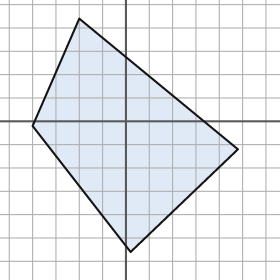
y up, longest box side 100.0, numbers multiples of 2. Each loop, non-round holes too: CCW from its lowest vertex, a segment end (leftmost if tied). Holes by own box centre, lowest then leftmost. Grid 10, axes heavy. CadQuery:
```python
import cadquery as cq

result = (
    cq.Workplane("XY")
    .moveTo(2.0, -56.0)
    .lineTo(48.0, -12.0)
    .lineTo(-20.0, 44.0)
    .lineTo(-40.0, -2.0)
    .close()
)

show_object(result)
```